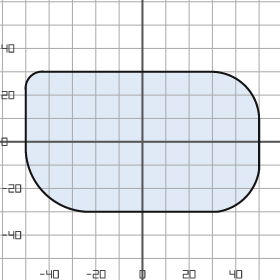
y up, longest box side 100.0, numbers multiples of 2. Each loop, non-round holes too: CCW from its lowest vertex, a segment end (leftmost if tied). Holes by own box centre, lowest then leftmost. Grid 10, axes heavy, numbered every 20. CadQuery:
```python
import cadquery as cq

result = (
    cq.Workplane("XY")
    .moveTo(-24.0, -30.0)
    .lineTo(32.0, -30.0)
    .threePointArc((44.0, -24.0), (50.0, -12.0))
    .lineTo(50.0, 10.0)
    .threePointArc((44.0, 24.0), (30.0, 30.0))
    .lineTo(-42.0, 30.0)
    .threePointArc((-48.0, 28.0), (-50.0, 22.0))
    .lineTo(-50.0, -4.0)
    .threePointArc((-42.0, -22.0), (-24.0, -30.0))
    .close()
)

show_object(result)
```